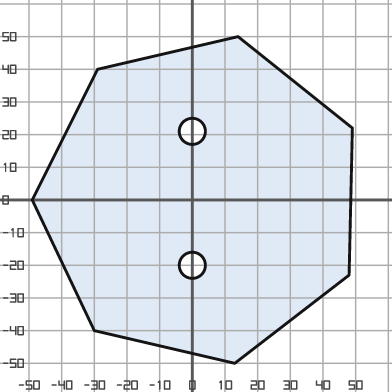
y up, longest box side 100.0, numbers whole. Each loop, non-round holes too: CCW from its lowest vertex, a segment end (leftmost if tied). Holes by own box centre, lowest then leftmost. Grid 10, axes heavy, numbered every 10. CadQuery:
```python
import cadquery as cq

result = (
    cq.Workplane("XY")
    .moveTo(13.0, -50.0)
    .lineTo(48.0, -23.0)
    .lineTo(49.0, 22.0)
    .lineTo(14.0, 50.0)
    .lineTo(-29.0, 40.0)
    .lineTo(-49.0, 0.0)
    .lineTo(-30.0, -40.0)
    .close()
    .moveTo(0.0, -20.0)
    .circle(4.0)
    .moveTo(0.0, 21.0)
    .circle(4.0)
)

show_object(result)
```